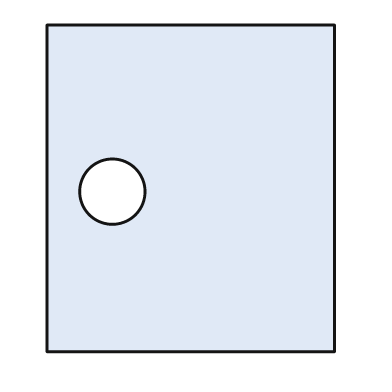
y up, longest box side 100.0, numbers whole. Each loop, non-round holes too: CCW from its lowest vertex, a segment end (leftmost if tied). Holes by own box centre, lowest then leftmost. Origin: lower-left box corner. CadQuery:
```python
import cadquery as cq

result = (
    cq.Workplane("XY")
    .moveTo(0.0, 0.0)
    .lineTo(88.0, 0.0)
    .lineTo(88.0, 100.0)
    .lineTo(0.0, 100.0)
    .close()
    .moveTo(20.0, 49.0)
    .circle(10.0)
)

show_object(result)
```